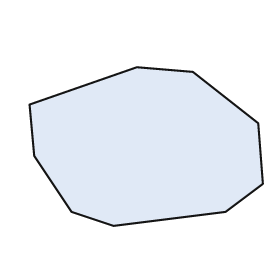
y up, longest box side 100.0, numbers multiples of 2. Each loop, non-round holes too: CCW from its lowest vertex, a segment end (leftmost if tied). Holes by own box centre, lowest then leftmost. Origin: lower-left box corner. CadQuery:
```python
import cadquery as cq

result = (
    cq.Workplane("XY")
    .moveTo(36.0, 0.0)
    .lineTo(84.0, 6.0)
    .lineTo(100.0, 18.0)
    .lineTo(98.0, 44.0)
    .lineTo(70.0, 66.0)
    .lineTo(46.0, 68.0)
    .lineTo(0.0, 52.0)
    .lineTo(2.0, 30.0)
    .lineTo(18.0, 6.0)
    .close()
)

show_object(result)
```